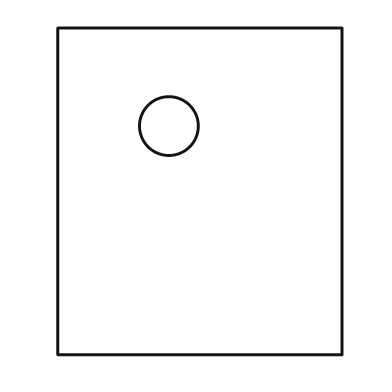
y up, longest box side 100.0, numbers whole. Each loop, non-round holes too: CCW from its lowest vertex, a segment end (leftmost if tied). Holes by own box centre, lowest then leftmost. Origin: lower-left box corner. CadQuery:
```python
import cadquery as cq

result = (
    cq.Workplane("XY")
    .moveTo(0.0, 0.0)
    .lineTo(87.0, 0.0)
    .lineTo(87.0, 100.0)
    .lineTo(0.0, 100.0)
    .close()
    .moveTo(34.0, 70.0)
    .circle(9.0)
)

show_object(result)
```